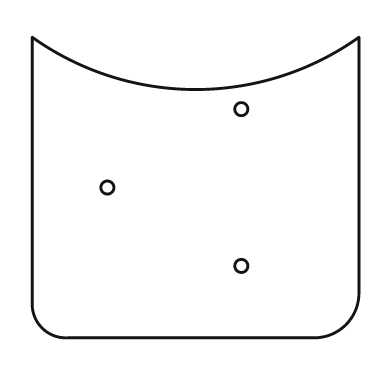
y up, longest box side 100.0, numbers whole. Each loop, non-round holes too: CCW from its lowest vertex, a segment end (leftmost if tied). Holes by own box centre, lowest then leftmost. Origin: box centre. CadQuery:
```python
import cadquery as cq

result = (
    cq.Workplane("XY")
    .moveTo(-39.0, -46.0)
    .lineTo(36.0, -46.0)
    .threePointArc((46.0, -42.0), (50.0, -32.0))
    .lineTo(50.0, 46.0)
    .threePointArc((0.0, 30.0), (-50.0, 46.0))
    .lineTo(-50.0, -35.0)
    .threePointArc((-47.0, -43.0), (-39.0, -46.0))
    .close()
    .moveTo(14.0, -24.0)
    .circle(2.0)
    .moveTo(-27.0, 0.0)
    .circle(2.0)
    .moveTo(14.0, 24.0)
    .circle(2.0)
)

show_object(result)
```